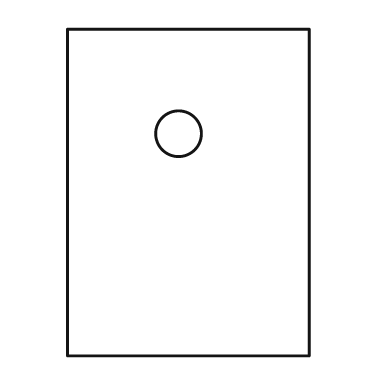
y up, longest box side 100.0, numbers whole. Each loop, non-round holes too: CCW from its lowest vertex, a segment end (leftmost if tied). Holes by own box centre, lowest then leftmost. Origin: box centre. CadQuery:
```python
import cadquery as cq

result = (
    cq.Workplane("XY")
    .moveTo(-37.0, -50.0)
    .lineTo(37.0, -50.0)
    .lineTo(37.0, 50.0)
    .lineTo(-37.0, 50.0)
    .close()
    .moveTo(-3.0, 18.0)
    .circle(7.0)
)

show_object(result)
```